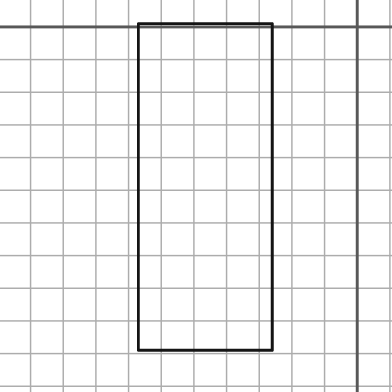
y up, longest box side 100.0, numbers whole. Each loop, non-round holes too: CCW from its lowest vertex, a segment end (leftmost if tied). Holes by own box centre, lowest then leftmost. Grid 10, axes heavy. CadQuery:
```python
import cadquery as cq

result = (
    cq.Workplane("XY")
    .moveTo(-67.0, -99.0)
    .lineTo(-26.0, -99.0)
    .lineTo(-26.0, 1.0)
    .lineTo(-67.0, 1.0)
    .close()
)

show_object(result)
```